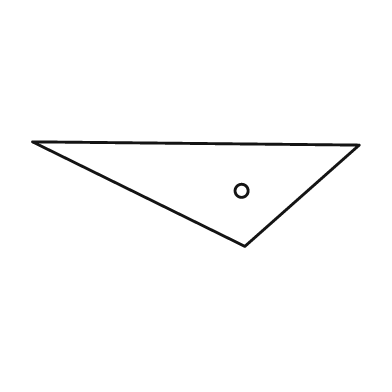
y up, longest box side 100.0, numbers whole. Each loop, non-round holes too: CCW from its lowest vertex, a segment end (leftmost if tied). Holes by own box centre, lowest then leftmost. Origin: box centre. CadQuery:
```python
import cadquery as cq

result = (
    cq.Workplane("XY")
    .moveTo(15.0, -16.0)
    .lineTo(50.0, 15.0)
    .lineTo(-50.0, 16.0)
    .close()
    .moveTo(14.0, 1.0)
    .circle(2.0)
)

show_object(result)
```